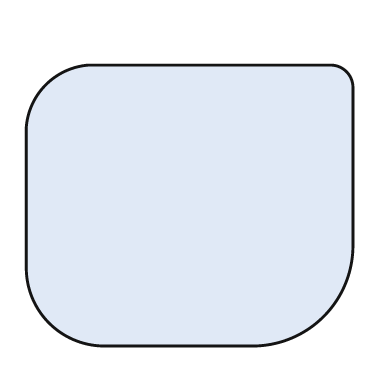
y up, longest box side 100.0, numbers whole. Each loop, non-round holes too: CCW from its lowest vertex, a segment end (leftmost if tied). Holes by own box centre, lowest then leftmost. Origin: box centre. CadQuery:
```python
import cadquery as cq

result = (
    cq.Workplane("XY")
    .moveTo(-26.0, -43.0)
    .lineTo(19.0, -43.0)
    .threePointArc((41.0, -34.0), (50.0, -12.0))
    .lineTo(50.0, 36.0)
    .threePointArc((48.0, 41.0), (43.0, 43.0))
    .lineTo(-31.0, 43.0)
    .threePointArc((-44.0, 37.0), (-50.0, 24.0))
    .lineTo(-50.0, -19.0)
    .threePointArc((-43.0, -36.0), (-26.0, -43.0))
    .close()
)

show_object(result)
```